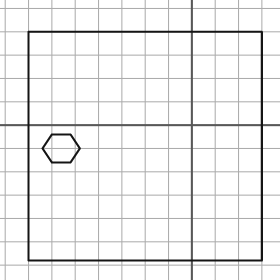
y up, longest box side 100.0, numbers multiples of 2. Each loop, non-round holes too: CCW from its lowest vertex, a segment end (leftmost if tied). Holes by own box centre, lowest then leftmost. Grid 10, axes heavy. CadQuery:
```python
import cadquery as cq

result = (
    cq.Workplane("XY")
    .moveTo(-70.0, -58.0)
    .lineTo(30.0, -58.0)
    .lineTo(30.0, 40.0)
    .lineTo(-70.0, 40.0)
    .close()
    .moveTo(-60.0, -16.0)
    .lineTo(-52.0, -16.0)
    .lineTo(-48.0, -10.0)
    .lineTo(-52.0, -4.0)
    .lineTo(-60.0, -4.0)
    .lineTo(-64.0, -10.0)
    .close()
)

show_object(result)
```